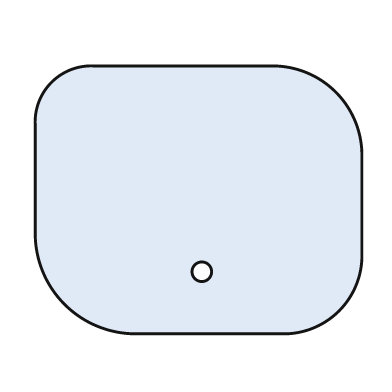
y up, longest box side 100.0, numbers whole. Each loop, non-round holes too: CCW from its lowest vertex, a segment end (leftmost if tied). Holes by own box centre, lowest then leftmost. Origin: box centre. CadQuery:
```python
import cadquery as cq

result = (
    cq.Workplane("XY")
    .moveTo(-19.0, -41.0)
    .lineTo(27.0, -41.0)
    .threePointArc((43.0, -34.0), (50.0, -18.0))
    .lineTo(50.0, 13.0)
    .threePointArc((42.0, 33.0), (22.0, 41.0))
    .lineTo(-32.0, 41.0)
    .threePointArc((-45.0, 36.0), (-50.0, 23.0))
    .lineTo(-50.0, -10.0)
    .threePointArc((-41.0, -32.0), (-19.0, -41.0))
    .close()
    .moveTo(1.0, -22.0)
    .circle(3.0)
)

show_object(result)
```